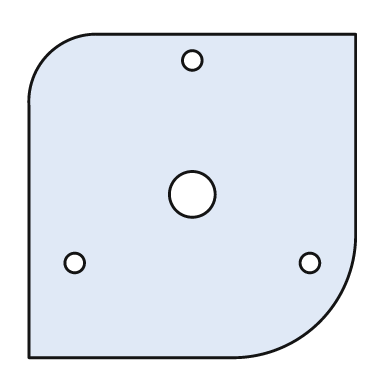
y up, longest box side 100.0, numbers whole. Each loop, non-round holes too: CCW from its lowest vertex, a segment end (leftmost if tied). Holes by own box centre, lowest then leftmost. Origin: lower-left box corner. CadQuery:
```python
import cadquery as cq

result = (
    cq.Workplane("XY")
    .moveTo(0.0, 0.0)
    .lineTo(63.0, 0.0)
    .threePointArc((89.0, 11.0), (100.0, 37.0))
    .lineTo(100.0, 99.0)
    .lineTo(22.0, 99.0)
    .threePointArc((6.0, 93.0), (0.0, 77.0))
    .close()
    .moveTo(14.0, 29.0)
    .circle(3.0)
    .moveTo(86.0, 29.0)
    .circle(3.0)
    .moveTo(50.0, 50.0)
    .circle(7.0)
    .moveTo(50.0, 91.0)
    .circle(3.0)
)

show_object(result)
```